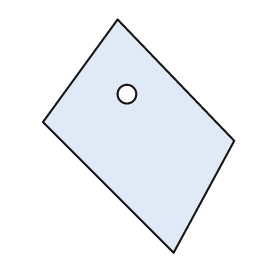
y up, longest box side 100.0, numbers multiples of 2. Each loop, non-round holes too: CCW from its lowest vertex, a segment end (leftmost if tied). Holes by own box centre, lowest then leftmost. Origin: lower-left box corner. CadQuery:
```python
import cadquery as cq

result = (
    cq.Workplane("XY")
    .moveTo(56.0, 0.0)
    .lineTo(82.0, 48.0)
    .lineTo(32.0, 100.0)
    .lineTo(0.0, 56.0)
    .close()
    .moveTo(36.0, 68.0)
    .circle(4.0)
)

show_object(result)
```